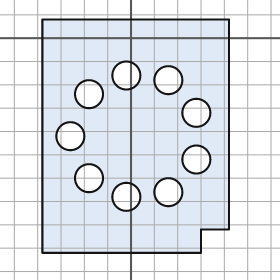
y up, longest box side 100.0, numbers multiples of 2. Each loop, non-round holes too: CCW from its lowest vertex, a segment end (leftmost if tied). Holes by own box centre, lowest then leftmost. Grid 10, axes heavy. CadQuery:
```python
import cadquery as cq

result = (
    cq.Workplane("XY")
    .moveTo(-38.0, -92.0)
    .lineTo(30.0, -92.0)
    .lineTo(30.0, -82.0)
    .lineTo(42.0, -82.0)
    .lineTo(42.0, 8.0)
    .lineTo(-38.0, 8.0)
    .close()
    .moveTo(-2.0, -68.0)
    .circle(6.0)
    .moveTo(16.0, -66.0)
    .circle(6.0)
    .moveTo(-18.0, -60.0)
    .circle(6.0)
    .moveTo(28.0, -52.0)
    .circle(6.0)
    .moveTo(-26.0, -42.0)
    .circle(6.0)
    .moveTo(28.0, -32.0)
    .circle(6.0)
    .moveTo(-18.0, -24.0)
    .circle(6.0)
    .moveTo(16.0, -18.0)
    .circle(6.0)
    .moveTo(-2.0, -16.0)
    .circle(6.0)
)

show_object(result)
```